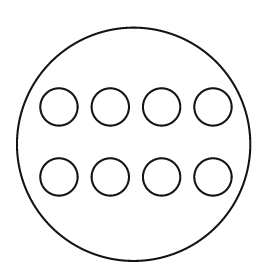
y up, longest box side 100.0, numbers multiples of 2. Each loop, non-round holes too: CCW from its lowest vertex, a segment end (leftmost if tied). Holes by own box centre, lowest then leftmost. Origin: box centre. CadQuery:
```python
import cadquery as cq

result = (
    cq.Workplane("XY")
    .moveTo(0.0, 0.0)
    .circle(50.0)
    .moveTo(-32.0, -14.0)
    .circle(8.0)
    .moveTo(-10.0, -14.0)
    .circle(8.0)
    .moveTo(12.0, -14.0)
    .circle(8.0)
    .moveTo(34.0, -14.0)
    .circle(8.0)
    .moveTo(-32.0, 16.0)
    .circle(8.0)
    .moveTo(-10.0, 16.0)
    .circle(8.0)
    .moveTo(12.0, 16.0)
    .circle(8.0)
    .moveTo(34.0, 16.0)
    .circle(8.0)
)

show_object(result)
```